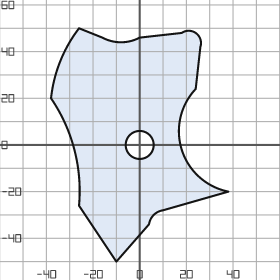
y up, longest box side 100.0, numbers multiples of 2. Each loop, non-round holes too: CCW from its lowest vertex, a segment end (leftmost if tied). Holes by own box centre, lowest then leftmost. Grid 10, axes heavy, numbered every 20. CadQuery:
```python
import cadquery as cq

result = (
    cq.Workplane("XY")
    .moveTo(-10.0, -50.0)
    .lineTo(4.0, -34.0)
    .threePointArc((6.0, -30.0), (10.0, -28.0))
    .lineTo(38.0, -20.0)
    .threePointArc((18.0, -2.0), (24.0, 24.0))
    .lineTo(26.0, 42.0)
    .threePointArc((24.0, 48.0), (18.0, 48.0))
    .lineTo(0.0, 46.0)
    .threePointArc((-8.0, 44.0), (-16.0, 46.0))
    .lineTo(-26.0, 50.0)
    .threePointArc((-34.0, 36.0), (-38.0, 20.0))
    .threePointArc((-28.0, -2.0), (-26.0, -26.0))
    .close()
    .moveTo(0.0, 0.0)
    .circle(6.0)
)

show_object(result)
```